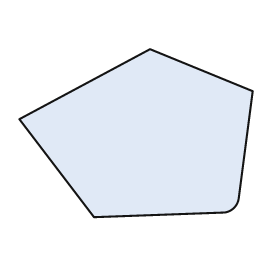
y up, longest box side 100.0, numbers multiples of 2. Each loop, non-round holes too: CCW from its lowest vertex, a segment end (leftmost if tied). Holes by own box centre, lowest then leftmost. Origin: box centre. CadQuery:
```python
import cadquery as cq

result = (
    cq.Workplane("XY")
    .moveTo(-18.0, -36.0)
    .lineTo(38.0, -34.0)
    .threePointArc((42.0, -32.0), (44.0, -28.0))
    .lineTo(50.0, 18.0)
    .lineTo(6.0, 36.0)
    .lineTo(-50.0, 6.0)
    .close()
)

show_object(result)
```